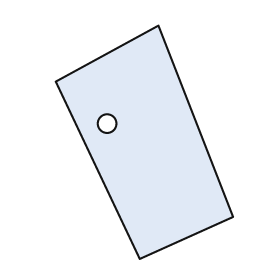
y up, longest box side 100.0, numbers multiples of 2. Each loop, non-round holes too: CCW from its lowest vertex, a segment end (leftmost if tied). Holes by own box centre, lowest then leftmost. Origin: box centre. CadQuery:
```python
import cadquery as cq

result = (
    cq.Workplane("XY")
    .moveTo(-2.0, -50.0)
    .lineTo(38.0, -32.0)
    .lineTo(6.0, 50.0)
    .lineTo(-38.0, 26.0)
    .close()
    .moveTo(-16.0, 8.0)
    .circle(4.0)
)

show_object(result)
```